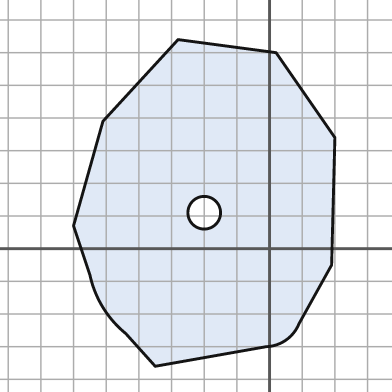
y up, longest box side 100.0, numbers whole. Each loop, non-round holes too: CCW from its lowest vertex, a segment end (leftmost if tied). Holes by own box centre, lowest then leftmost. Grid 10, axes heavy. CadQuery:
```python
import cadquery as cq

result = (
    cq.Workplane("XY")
    .moveTo(-35.0, -36.0)
    .lineTo(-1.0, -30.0)
    .threePointArc((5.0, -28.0), (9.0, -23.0))
    .lineTo(19.0, -5.0)
    .lineTo(20.0, 34.0)
    .lineTo(2.0, 60.0)
    .lineTo(-28.0, 64.0)
    .lineTo(-51.0, 39.0)
    .lineTo(-60.0, 7.0)
    .lineTo(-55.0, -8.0)
    .threePointArc((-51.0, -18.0), (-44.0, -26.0))
    .close()
    .moveTo(-20.0, 11.0)
    .circle(5.0)
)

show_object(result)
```